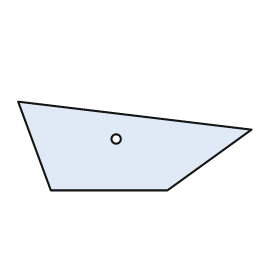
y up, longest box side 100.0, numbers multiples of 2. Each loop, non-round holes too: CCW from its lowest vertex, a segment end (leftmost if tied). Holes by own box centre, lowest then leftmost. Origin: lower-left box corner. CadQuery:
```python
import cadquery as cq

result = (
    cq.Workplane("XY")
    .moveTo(14.0, 0.0)
    .lineTo(64.0, 0.0)
    .lineTo(100.0, 26.0)
    .lineTo(0.0, 38.0)
    .close()
    .moveTo(42.0, 22.0)
    .circle(2.0)
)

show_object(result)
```